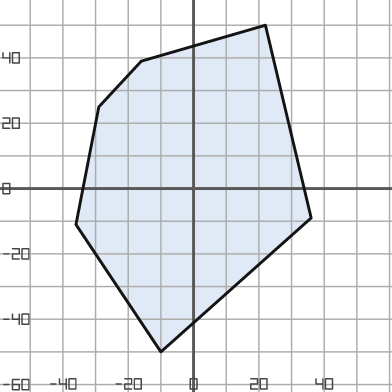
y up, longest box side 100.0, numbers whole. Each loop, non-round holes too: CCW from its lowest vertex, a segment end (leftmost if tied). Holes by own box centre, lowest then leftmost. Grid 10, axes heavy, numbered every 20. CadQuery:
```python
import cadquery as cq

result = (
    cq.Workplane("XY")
    .moveTo(-10.0, -50.0)
    .lineTo(36.0, -9.0)
    .lineTo(22.0, 50.0)
    .lineTo(-16.0, 39.0)
    .lineTo(-29.0, 25.0)
    .lineTo(-36.0, -11.0)
    .close()
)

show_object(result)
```